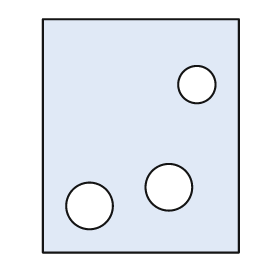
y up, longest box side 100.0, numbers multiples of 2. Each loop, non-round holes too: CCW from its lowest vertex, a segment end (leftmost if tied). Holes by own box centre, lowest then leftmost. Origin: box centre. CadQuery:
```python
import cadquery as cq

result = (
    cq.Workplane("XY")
    .moveTo(-42.0, -50.0)
    .lineTo(42.0, -50.0)
    .lineTo(42.0, 50.0)
    .lineTo(-42.0, 50.0)
    .close()
    .moveTo(-22.0, -30.0)
    .circle(10.0)
    .moveTo(12.0, -22.0)
    .circle(10.0)
    .moveTo(24.0, 22.0)
    .circle(8.0)
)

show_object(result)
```